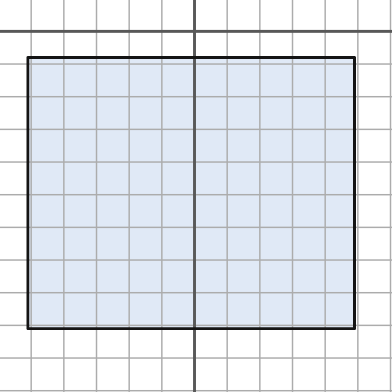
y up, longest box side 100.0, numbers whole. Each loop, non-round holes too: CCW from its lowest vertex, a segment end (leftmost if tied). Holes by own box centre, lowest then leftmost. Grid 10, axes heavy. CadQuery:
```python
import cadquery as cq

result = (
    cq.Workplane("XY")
    .moveTo(-51.0, -91.0)
    .lineTo(49.0, -91.0)
    .lineTo(49.0, -8.0)
    .lineTo(-51.0, -8.0)
    .close()
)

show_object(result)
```